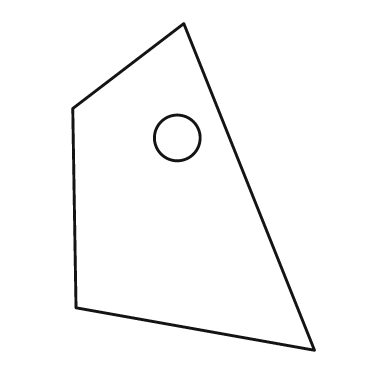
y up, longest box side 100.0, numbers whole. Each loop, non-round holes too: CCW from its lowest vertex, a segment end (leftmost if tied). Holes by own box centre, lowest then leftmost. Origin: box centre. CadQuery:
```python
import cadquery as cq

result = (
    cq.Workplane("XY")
    .moveTo(37.0, -50.0)
    .lineTo(-3.0, 50.0)
    .lineTo(-37.0, 24.0)
    .lineTo(-36.0, -37.0)
    .close()
    .moveTo(-5.0, 15.0)
    .circle(7.0)
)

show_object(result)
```